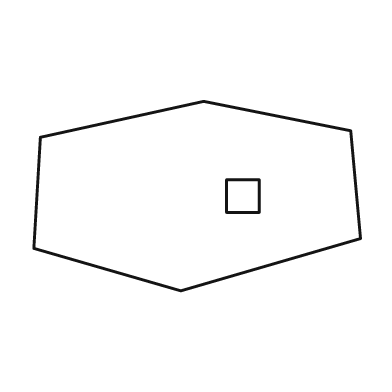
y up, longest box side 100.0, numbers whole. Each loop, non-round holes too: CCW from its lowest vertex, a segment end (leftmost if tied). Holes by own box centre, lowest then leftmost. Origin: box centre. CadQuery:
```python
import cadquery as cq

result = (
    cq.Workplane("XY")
    .moveTo(-5.0, -29.0)
    .lineTo(50.0, -13.0)
    .lineTo(47.0, 20.0)
    .lineTo(2.0, 29.0)
    .lineTo(-48.0, 18.0)
    .lineTo(-50.0, -16.0)
    .close()
    .moveTo(9.0, -5.0)
    .lineTo(19.0, -5.0)
    .lineTo(19.0, 5.0)
    .lineTo(9.0, 5.0)
    .close()
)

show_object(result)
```